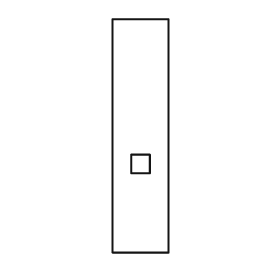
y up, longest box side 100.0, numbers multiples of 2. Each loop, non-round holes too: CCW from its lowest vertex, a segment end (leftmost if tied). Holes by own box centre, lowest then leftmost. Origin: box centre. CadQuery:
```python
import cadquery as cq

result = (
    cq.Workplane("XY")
    .moveTo(-12.0, -50.0)
    .lineTo(12.0, -50.0)
    .lineTo(12.0, 50.0)
    .lineTo(-12.0, 50.0)
    .close()
    .moveTo(-4.0, -16.0)
    .lineTo(4.0, -16.0)
    .lineTo(4.0, -8.0)
    .lineTo(-4.0, -8.0)
    .close()
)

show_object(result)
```